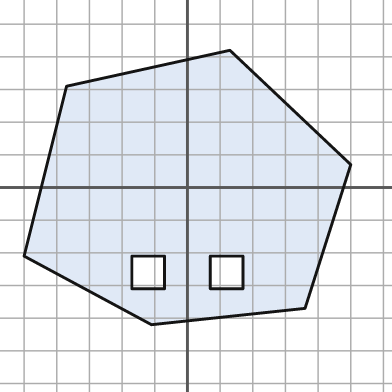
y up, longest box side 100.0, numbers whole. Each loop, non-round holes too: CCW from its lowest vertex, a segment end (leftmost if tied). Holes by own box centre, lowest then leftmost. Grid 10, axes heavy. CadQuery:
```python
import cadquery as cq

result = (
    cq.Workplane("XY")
    .moveTo(-11.0, -42.0)
    .lineTo(36.0, -37.0)
    .lineTo(50.0, 7.0)
    .lineTo(13.0, 42.0)
    .lineTo(-37.0, 31.0)
    .lineTo(-50.0, -21.0)
    .close()
    .moveTo(-17.0, -31.0)
    .lineTo(-7.0, -31.0)
    .lineTo(-7.0, -21.0)
    .lineTo(-17.0, -21.0)
    .close()
    .moveTo(7.0, -31.0)
    .lineTo(17.0, -31.0)
    .lineTo(17.0, -21.0)
    .lineTo(7.0, -21.0)
    .close()
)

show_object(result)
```